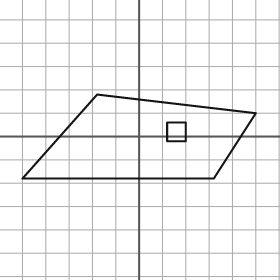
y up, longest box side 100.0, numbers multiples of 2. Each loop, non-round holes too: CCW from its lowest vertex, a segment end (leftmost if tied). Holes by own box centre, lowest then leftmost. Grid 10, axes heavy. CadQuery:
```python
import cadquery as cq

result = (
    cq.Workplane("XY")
    .moveTo(-50.0, -18.0)
    .lineTo(32.0, -18.0)
    .lineTo(50.0, 10.0)
    .lineTo(-18.0, 18.0)
    .close()
    .moveTo(12.0, -2.0)
    .lineTo(20.0, -2.0)
    .lineTo(20.0, 6.0)
    .lineTo(12.0, 6.0)
    .close()
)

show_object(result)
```